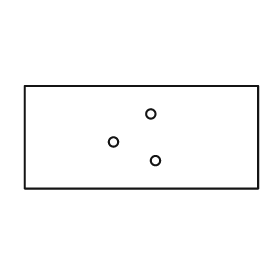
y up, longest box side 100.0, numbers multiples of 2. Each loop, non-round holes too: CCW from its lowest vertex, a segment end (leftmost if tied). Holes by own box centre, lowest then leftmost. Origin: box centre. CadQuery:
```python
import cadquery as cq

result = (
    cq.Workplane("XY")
    .moveTo(-50.0, -22.0)
    .lineTo(50.0, -22.0)
    .lineTo(50.0, 22.0)
    .lineTo(-50.0, 22.0)
    .close()
    .moveTo(6.0, -10.0)
    .circle(2.0)
    .moveTo(-12.0, -2.0)
    .circle(2.0)
    .moveTo(4.0, 10.0)
    .circle(2.0)
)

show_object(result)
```